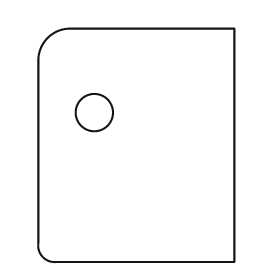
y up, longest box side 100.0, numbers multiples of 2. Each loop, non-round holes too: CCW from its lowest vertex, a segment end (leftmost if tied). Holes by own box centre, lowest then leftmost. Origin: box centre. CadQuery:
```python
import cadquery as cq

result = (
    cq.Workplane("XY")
    .moveTo(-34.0, -50.0)
    .lineTo(42.0, -50.0)
    .lineTo(42.0, 50.0)
    .lineTo(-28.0, 50.0)
    .threePointArc((-38.0, 46.0), (-42.0, 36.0))
    .lineTo(-42.0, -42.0)
    .threePointArc((-40.0, -48.0), (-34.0, -50.0))
    .close()
    .moveTo(-18.0, 14.0)
    .circle(8.0)
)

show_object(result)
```